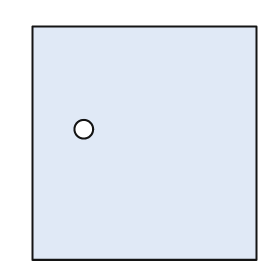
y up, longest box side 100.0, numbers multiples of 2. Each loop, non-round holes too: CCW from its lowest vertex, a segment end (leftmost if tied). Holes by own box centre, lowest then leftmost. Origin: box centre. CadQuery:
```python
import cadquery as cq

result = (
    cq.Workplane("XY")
    .moveTo(-48.0, -50.0)
    .lineTo(48.0, -50.0)
    .lineTo(48.0, 50.0)
    .lineTo(-48.0, 50.0)
    .close()
    .moveTo(-26.0, 6.0)
    .circle(4.0)
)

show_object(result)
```